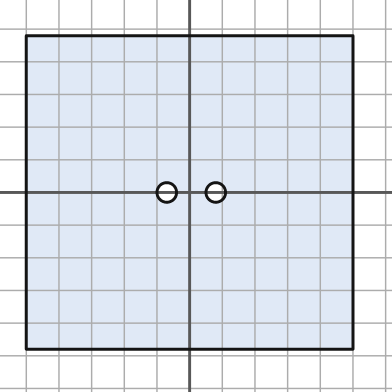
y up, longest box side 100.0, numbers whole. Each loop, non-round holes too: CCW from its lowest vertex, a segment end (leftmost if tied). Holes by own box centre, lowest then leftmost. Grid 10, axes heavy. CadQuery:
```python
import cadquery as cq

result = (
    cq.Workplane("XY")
    .moveTo(-50.0, -48.0)
    .lineTo(50.0, -48.0)
    .lineTo(50.0, 48.0)
    .lineTo(-50.0, 48.0)
    .close()
    .moveTo(-7.0, 0.0)
    .circle(3.0)
    .moveTo(8.0, 0.0)
    .circle(3.0)
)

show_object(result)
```